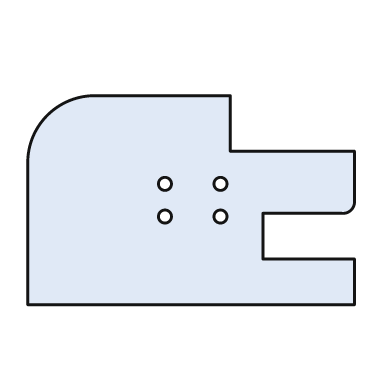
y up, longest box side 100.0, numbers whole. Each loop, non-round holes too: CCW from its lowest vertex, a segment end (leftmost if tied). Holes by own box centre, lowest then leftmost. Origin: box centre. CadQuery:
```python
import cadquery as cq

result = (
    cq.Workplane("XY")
    .moveTo(-50.0, -32.0)
    .lineTo(50.0, -32.0)
    .lineTo(50.0, -18.0)
    .lineTo(22.0, -18.0)
    .lineTo(22.0, -4.0)
    .lineTo(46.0, -4.0)
    .threePointArc((49.0, -3.0), (50.0, 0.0))
    .lineTo(50.0, 15.0)
    .lineTo(12.0, 15.0)
    .lineTo(12.0, 32.0)
    .lineTo(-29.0, 32.0)
    .threePointArc((-44.0, 26.0), (-50.0, 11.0))
    .close()
    .moveTo(-8.0, -5.0)
    .circle(2.0)
    .moveTo(9.0, -5.0)
    .circle(2.0)
    .moveTo(-8.0, 5.0)
    .circle(2.0)
    .moveTo(9.0, 5.0)
    .circle(2.0)
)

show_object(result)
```